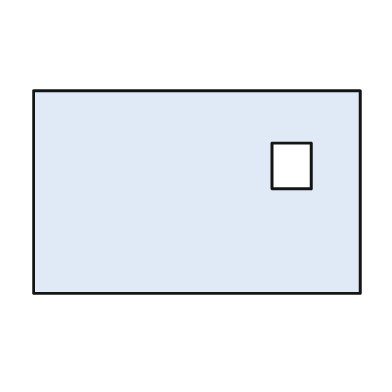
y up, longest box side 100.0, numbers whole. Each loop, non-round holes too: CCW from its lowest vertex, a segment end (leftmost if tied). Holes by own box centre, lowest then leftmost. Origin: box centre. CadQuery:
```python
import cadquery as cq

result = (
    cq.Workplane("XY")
    .moveTo(-50.0, -31.0)
    .lineTo(50.0, -31.0)
    .lineTo(50.0, 31.0)
    .lineTo(-50.0, 31.0)
    .close()
    .moveTo(23.0, 1.0)
    .lineTo(35.0, 1.0)
    .lineTo(35.0, 15.0)
    .lineTo(23.0, 15.0)
    .close()
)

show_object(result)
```